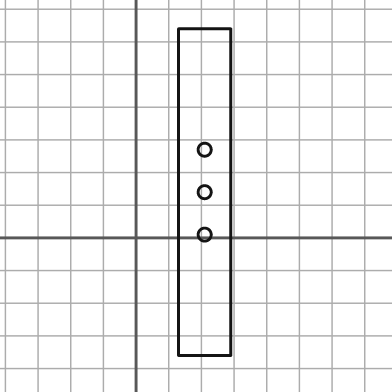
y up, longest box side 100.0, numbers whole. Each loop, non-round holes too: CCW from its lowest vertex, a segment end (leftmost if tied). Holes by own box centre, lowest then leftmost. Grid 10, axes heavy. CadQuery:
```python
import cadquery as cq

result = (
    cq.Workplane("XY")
    .moveTo(13.0, -36.0)
    .lineTo(29.0, -36.0)
    .lineTo(29.0, 64.0)
    .lineTo(13.0, 64.0)
    .close()
    .moveTo(21.0, 1.0)
    .circle(2.0)
    .moveTo(21.0, 14.0)
    .circle(2.0)
    .moveTo(21.0, 27.0)
    .circle(2.0)
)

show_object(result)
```